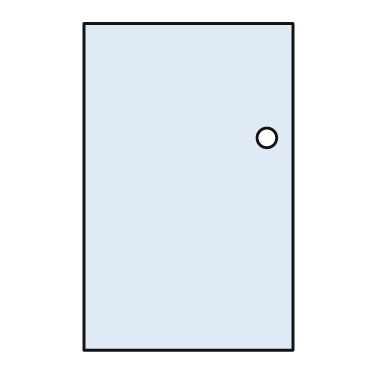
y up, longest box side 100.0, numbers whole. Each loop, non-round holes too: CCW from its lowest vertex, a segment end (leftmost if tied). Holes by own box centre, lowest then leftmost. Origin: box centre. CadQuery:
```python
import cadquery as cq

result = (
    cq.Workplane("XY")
    .moveTo(-32.0, -50.0)
    .lineTo(32.0, -50.0)
    .lineTo(32.0, 50.0)
    .lineTo(-32.0, 50.0)
    .close()
    .moveTo(24.0, 15.0)
    .circle(3.0)
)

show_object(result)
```